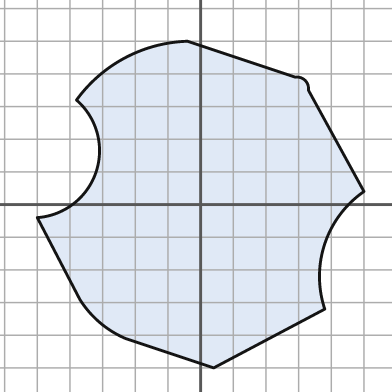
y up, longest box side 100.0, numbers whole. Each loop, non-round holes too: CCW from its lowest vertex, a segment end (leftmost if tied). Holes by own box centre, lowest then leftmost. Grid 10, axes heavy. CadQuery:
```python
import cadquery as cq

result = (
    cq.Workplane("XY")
    .moveTo(4.0, -50.0)
    .lineTo(38.0, -32.0)
    .threePointArc((38.0, -12.0), (50.0, 4.0))
    .lineTo(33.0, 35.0)
    .threePointArc((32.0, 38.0), (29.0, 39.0))
    .lineTo(-4.0, 50.0)
    .threePointArc((-23.0, 45.0), (-38.0, 32.0))
    .threePointArc((-32.0, 10.0), (-50.0, -4.0))
    .lineTo(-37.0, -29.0)
    .threePointArc((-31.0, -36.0), (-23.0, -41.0))
    .close()
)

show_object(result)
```